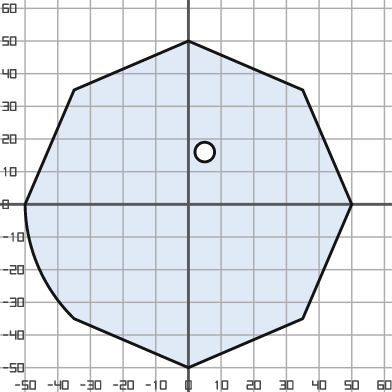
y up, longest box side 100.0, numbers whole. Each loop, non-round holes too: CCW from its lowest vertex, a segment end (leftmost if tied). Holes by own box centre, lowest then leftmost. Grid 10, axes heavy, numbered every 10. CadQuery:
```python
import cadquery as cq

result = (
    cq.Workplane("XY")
    .moveTo(0.0, -50.0)
    .lineTo(35.0, -35.0)
    .lineTo(50.0, 0.0)
    .lineTo(35.0, 35.0)
    .lineTo(0.0, 50.0)
    .lineTo(-35.0, 35.0)
    .lineTo(-50.0, 0.0)
    .threePointArc((-46.0, -19.0), (-35.0, -35.0))
    .close()
    .moveTo(5.0, 16.0)
    .circle(3.0)
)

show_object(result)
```